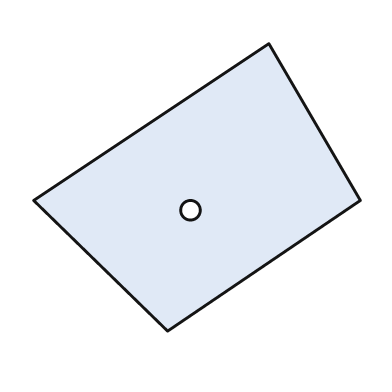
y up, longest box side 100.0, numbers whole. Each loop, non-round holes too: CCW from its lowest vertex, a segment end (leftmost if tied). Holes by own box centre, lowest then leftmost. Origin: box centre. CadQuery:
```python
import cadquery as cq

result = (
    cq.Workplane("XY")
    .moveTo(-9.0, -44.0)
    .lineTo(50.0, -4.0)
    .lineTo(22.0, 44.0)
    .lineTo(-50.0, -4.0)
    .close()
    .moveTo(-2.0, -7.0)
    .circle(3.0)
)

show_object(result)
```